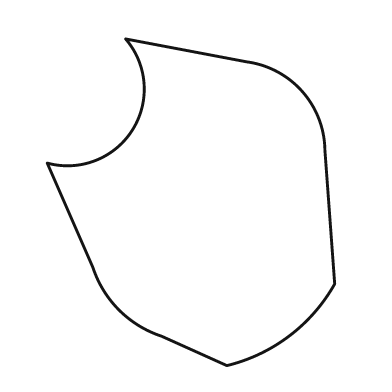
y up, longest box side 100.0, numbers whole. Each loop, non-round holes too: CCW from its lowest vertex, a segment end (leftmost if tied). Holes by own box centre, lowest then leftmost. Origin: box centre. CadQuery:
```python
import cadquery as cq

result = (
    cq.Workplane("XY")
    .moveTo(11.0, -50.0)
    .threePointArc((30.0, -41.0), (44.0, -25.0))
    .lineTo(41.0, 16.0)
    .threePointArc((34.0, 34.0), (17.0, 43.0))
    .lineTo(-20.0, 50.0)
    .threePointArc((-18.0, 22.0), (-44.0, 12.0))
    .lineTo(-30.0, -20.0)
    .threePointArc((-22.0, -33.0), (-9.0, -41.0))
    .close()
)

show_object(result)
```